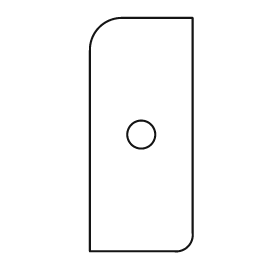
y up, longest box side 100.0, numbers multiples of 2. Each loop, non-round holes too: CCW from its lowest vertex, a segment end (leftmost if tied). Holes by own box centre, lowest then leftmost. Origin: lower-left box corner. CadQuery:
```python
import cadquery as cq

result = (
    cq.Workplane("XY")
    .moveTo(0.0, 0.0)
    .lineTo(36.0, 0.0)
    .threePointArc((42.0, 2.0), (44.0, 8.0))
    .lineTo(44.0, 100.0)
    .lineTo(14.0, 100.0)
    .threePointArc((4.0, 96.0), (0.0, 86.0))
    .close()
    .moveTo(22.0, 50.0)
    .circle(6.0)
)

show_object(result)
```